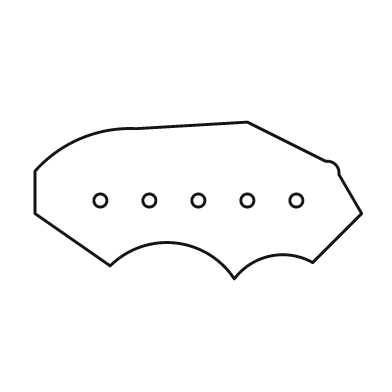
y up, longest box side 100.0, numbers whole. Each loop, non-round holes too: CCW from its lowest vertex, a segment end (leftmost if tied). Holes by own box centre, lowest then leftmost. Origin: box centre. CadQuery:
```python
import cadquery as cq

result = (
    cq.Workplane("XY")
    .moveTo(11.0, -24.0)
    .threePointArc((22.0, -17.0), (35.0, -19.0))
    .lineTo(50.0, -4.0)
    .lineTo(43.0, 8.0)
    .threePointArc((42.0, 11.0), (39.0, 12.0))
    .lineTo(15.0, 24.0)
    .lineTo(-19.0, 22.0)
    .threePointArc((-36.0, 19.0), (-50.0, 9.0))
    .lineTo(-50.0, -4.0)
    .lineTo(-27.0, -20.0)
    .threePointArc((-7.0, -13.0), (11.0, -24.0))
    .close()
    .moveTo(-30.0, 0.0)
    .circle(2.0)
    .moveTo(-15.0, 0.0)
    .circle(2.0)
    .moveTo(0.0, 0.0)
    .circle(2.0)
    .moveTo(15.0, 0.0)
    .circle(2.0)
    .moveTo(30.0, 0.0)
    .circle(2.0)
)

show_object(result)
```